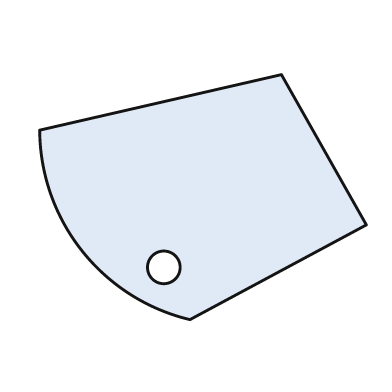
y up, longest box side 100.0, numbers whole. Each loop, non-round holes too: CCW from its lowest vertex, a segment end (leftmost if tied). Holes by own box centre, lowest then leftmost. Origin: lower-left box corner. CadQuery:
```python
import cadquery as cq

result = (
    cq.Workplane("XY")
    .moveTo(46.0, 0.0)
    .lineTo(100.0, 29.0)
    .lineTo(74.0, 75.0)
    .lineTo(0.0, 58.0)
    .threePointArc((13.0, 21.0), (46.0, 0.0))
    .close()
    .moveTo(38.0, 16.0)
    .circle(5.0)
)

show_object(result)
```